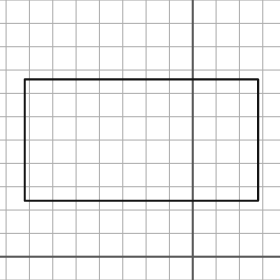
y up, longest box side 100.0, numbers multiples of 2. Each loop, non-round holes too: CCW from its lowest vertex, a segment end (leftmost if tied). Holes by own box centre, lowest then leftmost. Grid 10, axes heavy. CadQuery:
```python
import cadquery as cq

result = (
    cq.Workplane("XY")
    .moveTo(-72.0, 24.0)
    .lineTo(28.0, 24.0)
    .lineTo(28.0, 76.0)
    .lineTo(-72.0, 76.0)
    .close()
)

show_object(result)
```